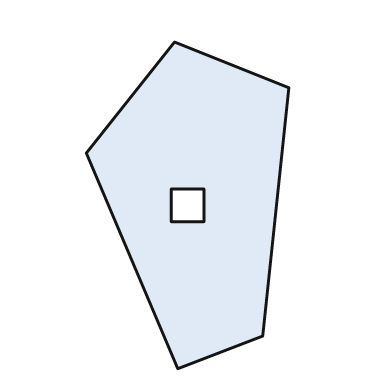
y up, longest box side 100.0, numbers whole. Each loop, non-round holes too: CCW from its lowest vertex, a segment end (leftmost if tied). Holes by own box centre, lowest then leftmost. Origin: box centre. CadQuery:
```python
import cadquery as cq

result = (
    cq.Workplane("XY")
    .moveTo(-3.0, -50.0)
    .lineTo(23.0, -40.0)
    .lineTo(31.0, 36.0)
    .lineTo(-4.0, 50.0)
    .lineTo(-31.0, 16.0)
    .close()
    .moveTo(-5.0, -5.0)
    .lineTo(5.0, -5.0)
    .lineTo(5.0, 5.0)
    .lineTo(-5.0, 5.0)
    .close()
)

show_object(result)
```